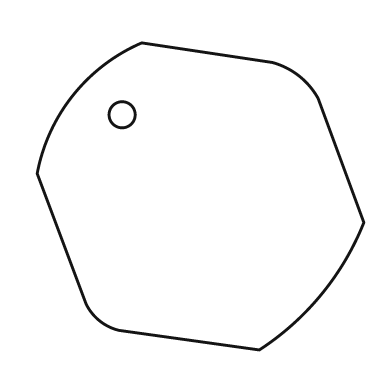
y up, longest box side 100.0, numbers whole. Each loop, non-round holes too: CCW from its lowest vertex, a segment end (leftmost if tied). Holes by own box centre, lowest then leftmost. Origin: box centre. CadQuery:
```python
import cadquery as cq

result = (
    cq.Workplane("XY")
    .moveTo(18.0, -47.0)
    .threePointArc((37.0, -30.0), (50.0, -8.0))
    .lineTo(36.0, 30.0)
    .threePointArc((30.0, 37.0), (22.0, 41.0))
    .lineTo(-18.0, 47.0)
    .threePointArc((-39.0, 31.0), (-50.0, 7.0))
    .lineTo(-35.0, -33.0)
    .threePointArc((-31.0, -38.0), (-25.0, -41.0))
    .close()
    .moveTo(-24.0, 25.0)
    .circle(4.0)
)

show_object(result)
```